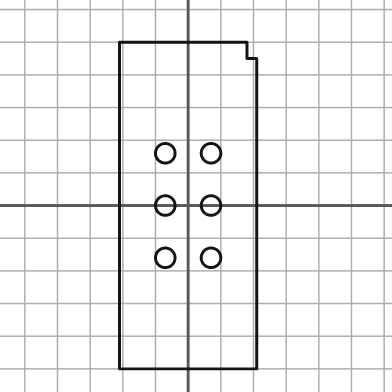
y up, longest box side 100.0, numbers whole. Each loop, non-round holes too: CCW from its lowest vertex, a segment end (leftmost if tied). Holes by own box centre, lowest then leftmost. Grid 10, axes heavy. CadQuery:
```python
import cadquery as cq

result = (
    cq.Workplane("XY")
    .moveTo(-21.0, -50.0)
    .lineTo(21.0, -50.0)
    .lineTo(21.0, 45.0)
    .lineTo(18.0, 45.0)
    .lineTo(18.0, 50.0)
    .lineTo(-21.0, 50.0)
    .close()
    .moveTo(-7.0, -16.0)
    .circle(3.0)
    .moveTo(7.0, -16.0)
    .circle(3.0)
    .moveTo(-7.0, 0.0)
    .circle(3.0)
    .moveTo(7.0, 0.0)
    .circle(3.0)
    .moveTo(-7.0, 16.0)
    .circle(3.0)
    .moveTo(7.0, 16.0)
    .circle(3.0)
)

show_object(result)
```